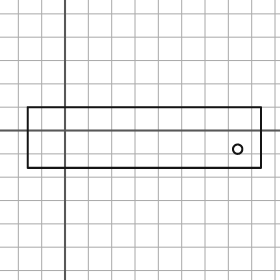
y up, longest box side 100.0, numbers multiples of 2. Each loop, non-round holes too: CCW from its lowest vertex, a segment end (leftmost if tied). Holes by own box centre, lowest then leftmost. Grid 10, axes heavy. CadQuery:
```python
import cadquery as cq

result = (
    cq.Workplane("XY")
    .moveTo(-16.0, -16.0)
    .lineTo(84.0, -16.0)
    .lineTo(84.0, 10.0)
    .lineTo(-16.0, 10.0)
    .close()
    .moveTo(74.0, -8.0)
    .circle(2.0)
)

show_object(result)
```